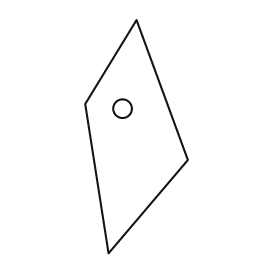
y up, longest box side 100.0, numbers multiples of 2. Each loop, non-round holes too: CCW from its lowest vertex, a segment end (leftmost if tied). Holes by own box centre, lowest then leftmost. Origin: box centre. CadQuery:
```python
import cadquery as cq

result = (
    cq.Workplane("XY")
    .moveTo(-12.0, -50.0)
    .lineTo(22.0, -10.0)
    .lineTo(0.0, 50.0)
    .lineTo(-22.0, 14.0)
    .close()
    .moveTo(-6.0, 12.0)
    .circle(4.0)
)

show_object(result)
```